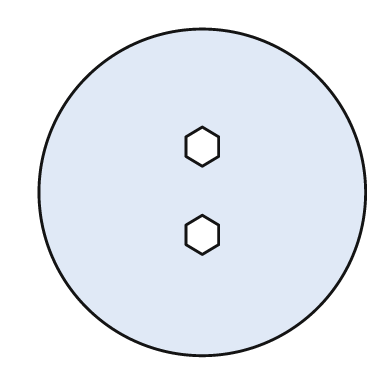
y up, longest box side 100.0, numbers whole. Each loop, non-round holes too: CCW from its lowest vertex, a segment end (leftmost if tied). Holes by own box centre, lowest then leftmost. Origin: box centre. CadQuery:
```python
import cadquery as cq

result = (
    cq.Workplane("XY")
    .moveTo(0.0, 0.0)
    .circle(50.0)
    .moveTo(0.0, -19.0)
    .lineTo(5.0, -16.0)
    .lineTo(5.0, -10.0)
    .lineTo(0.0, -7.0)
    .lineTo(-5.0, -10.0)
    .lineTo(-5.0, -16.0)
    .close()
    .moveTo(0.0, 8.0)
    .lineTo(5.0, 11.0)
    .lineTo(5.0, 17.0)
    .lineTo(0.0, 20.0)
    .lineTo(-5.0, 17.0)
    .lineTo(-5.0, 11.0)
    .close()
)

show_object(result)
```